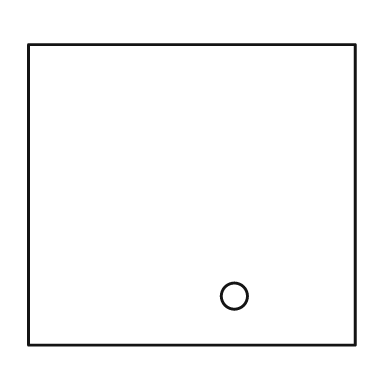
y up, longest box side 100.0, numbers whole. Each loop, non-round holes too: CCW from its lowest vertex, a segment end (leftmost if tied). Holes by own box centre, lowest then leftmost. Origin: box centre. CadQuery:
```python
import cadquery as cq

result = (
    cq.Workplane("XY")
    .moveTo(-50.0, -46.0)
    .lineTo(50.0, -46.0)
    .lineTo(50.0, 46.0)
    .lineTo(-50.0, 46.0)
    .close()
    .moveTo(13.0, -31.0)
    .circle(4.0)
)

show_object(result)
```